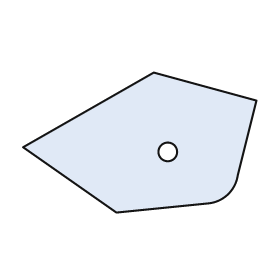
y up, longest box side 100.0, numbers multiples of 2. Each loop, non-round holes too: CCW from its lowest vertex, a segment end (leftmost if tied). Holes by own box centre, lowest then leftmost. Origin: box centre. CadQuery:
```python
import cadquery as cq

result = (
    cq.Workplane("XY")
    .moveTo(-10.0, -30.0)
    .lineTo(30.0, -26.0)
    .threePointArc((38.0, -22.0), (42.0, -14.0))
    .lineTo(50.0, 18.0)
    .lineTo(6.0, 30.0)
    .lineTo(-50.0, -2.0)
    .close()
    .moveTo(12.0, -4.0)
    .circle(4.0)
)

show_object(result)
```